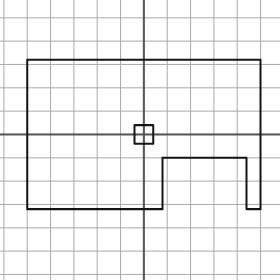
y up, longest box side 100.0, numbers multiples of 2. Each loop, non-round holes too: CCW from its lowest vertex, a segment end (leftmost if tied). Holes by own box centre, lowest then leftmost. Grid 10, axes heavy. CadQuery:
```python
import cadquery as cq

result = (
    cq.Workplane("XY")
    .moveTo(-50.0, -32.0)
    .lineTo(8.0, -32.0)
    .lineTo(8.0, -10.0)
    .lineTo(44.0, -10.0)
    .lineTo(44.0, -32.0)
    .lineTo(50.0, -32.0)
    .lineTo(50.0, 32.0)
    .lineTo(-50.0, 32.0)
    .close()
    .moveTo(-4.0, -4.0)
    .lineTo(4.0, -4.0)
    .lineTo(4.0, 4.0)
    .lineTo(-4.0, 4.0)
    .close()
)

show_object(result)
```